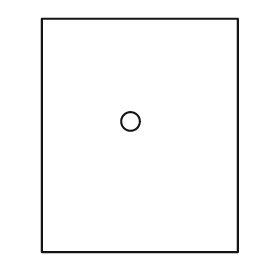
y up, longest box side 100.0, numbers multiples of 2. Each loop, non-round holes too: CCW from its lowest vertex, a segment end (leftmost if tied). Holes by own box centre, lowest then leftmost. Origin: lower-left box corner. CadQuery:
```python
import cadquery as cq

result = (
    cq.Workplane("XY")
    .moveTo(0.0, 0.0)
    .lineTo(84.0, 0.0)
    .lineTo(84.0, 100.0)
    .lineTo(0.0, 100.0)
    .close()
    .moveTo(38.0, 56.0)
    .circle(4.0)
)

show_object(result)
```